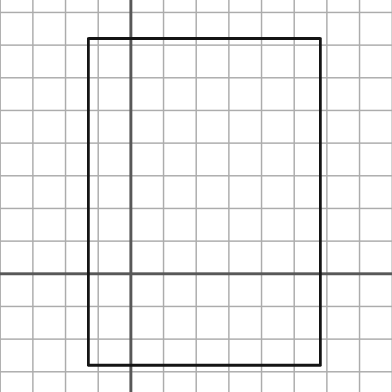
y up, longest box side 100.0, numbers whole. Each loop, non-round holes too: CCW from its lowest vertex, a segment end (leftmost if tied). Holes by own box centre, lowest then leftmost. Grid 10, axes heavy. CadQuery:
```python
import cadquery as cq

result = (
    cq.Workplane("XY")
    .moveTo(-13.0, -28.0)
    .lineTo(58.0, -28.0)
    .lineTo(58.0, 72.0)
    .lineTo(-13.0, 72.0)
    .close()
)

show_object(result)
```